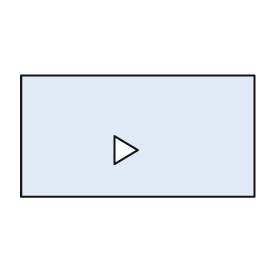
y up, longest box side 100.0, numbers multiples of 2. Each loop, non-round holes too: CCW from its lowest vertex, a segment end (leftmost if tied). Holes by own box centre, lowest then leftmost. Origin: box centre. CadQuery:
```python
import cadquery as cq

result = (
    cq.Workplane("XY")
    .moveTo(-50.0, -26.0)
    .lineTo(50.0, -26.0)
    .lineTo(50.0, 26.0)
    .lineTo(-50.0, 26.0)
    .close()
    .moveTo(-10.0, -12.0)
    .lineTo(0.0, -6.0)
    .lineTo(-10.0, 0.0)
    .close()
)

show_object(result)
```